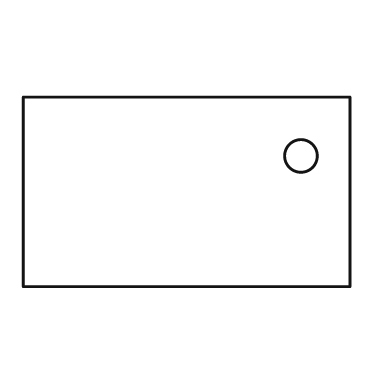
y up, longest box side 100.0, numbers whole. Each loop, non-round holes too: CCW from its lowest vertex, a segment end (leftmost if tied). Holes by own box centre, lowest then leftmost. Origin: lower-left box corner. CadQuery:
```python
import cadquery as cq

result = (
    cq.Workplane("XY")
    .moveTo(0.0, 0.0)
    .lineTo(100.0, 0.0)
    .lineTo(100.0, 58.0)
    .lineTo(0.0, 58.0)
    .close()
    .moveTo(85.0, 40.0)
    .circle(5.0)
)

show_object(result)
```